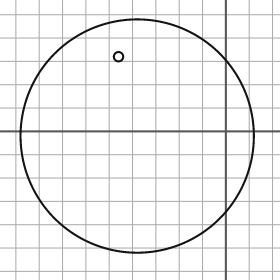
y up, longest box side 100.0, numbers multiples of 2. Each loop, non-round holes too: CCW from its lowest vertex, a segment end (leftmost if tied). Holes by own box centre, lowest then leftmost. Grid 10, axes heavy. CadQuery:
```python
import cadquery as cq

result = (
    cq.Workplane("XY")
    .moveTo(-38.0, -2.0)
    .circle(50.0)
    .moveTo(-46.0, 32.0)
    .circle(2.0)
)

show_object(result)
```